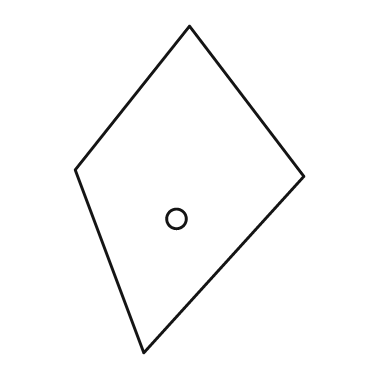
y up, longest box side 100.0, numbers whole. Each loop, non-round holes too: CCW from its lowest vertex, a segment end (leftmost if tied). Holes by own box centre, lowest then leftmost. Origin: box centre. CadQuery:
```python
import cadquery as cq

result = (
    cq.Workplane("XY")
    .moveTo(-14.0, -50.0)
    .lineTo(35.0, 4.0)
    .lineTo(0.0, 50.0)
    .lineTo(-35.0, 6.0)
    .close()
    .moveTo(-4.0, -9.0)
    .circle(3.0)
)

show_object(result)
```